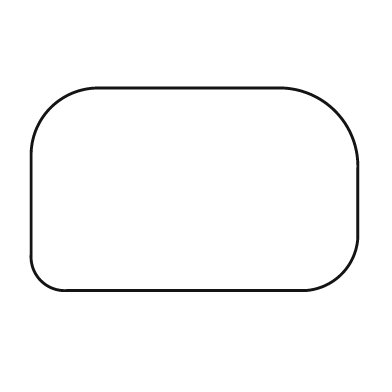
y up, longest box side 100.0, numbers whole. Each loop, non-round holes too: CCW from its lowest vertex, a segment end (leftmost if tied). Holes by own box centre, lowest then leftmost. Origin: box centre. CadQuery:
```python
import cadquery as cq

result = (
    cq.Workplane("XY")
    .moveTo(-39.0, -31.0)
    .lineTo(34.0, -31.0)
    .threePointArc((45.0, -26.0), (50.0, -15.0))
    .lineTo(50.0, 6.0)
    .threePointArc((43.0, 24.0), (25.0, 31.0))
    .lineTo(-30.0, 31.0)
    .threePointArc((-44.0, 25.0), (-50.0, 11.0))
    .lineTo(-50.0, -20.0)
    .threePointArc((-47.0, -28.0), (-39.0, -31.0))
    .close()
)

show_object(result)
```